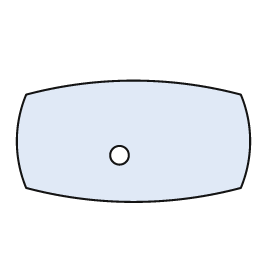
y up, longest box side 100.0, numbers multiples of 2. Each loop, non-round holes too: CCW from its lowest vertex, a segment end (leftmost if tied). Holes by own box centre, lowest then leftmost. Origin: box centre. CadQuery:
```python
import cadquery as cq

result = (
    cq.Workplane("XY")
    .moveTo(-46.0, -20.0)
    .threePointArc((0.0, -26.0), (46.0, -20.0))
    .threePointArc((50.0, 0.0), (46.0, 20.0))
    .threePointArc((0.0, 26.0), (-46.0, 20.0))
    .threePointArc((-50.0, 0.0), (-46.0, -20.0))
    .close()
    .moveTo(-6.0, -6.0)
    .circle(4.0)
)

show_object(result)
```